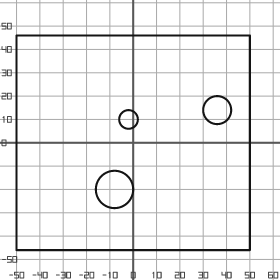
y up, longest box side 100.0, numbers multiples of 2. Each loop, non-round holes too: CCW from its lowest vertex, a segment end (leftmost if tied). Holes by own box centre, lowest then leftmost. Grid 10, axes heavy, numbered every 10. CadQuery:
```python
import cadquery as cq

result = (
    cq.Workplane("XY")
    .moveTo(-50.0, -46.0)
    .lineTo(50.0, -46.0)
    .lineTo(50.0, 46.0)
    .lineTo(-50.0, 46.0)
    .close()
    .moveTo(-8.0, -20.0)
    .circle(8.0)
    .moveTo(-2.0, 10.0)
    .circle(4.0)
    .moveTo(36.0, 14.0)
    .circle(6.0)
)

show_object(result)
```